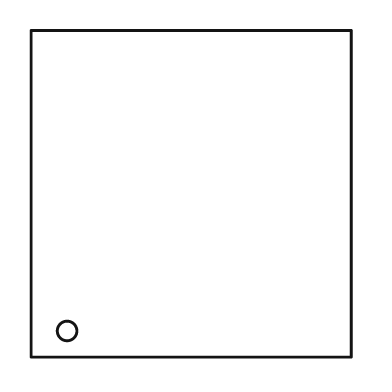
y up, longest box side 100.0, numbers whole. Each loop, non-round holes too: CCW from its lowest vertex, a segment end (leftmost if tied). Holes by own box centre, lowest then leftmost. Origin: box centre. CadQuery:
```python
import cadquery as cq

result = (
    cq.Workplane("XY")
    .moveTo(-49.0, -50.0)
    .lineTo(49.0, -50.0)
    .lineTo(49.0, 50.0)
    .lineTo(-49.0, 50.0)
    .close()
    .moveTo(-38.0, -42.0)
    .circle(3.0)
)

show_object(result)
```